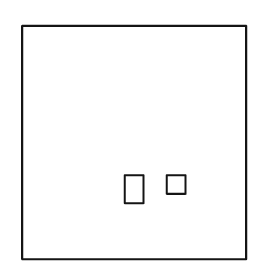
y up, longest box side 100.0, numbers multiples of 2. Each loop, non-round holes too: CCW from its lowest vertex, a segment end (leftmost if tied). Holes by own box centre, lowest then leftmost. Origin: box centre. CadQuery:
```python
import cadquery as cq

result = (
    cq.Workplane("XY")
    .moveTo(-48.0, -50.0)
    .lineTo(48.0, -50.0)
    .lineTo(48.0, 50.0)
    .lineTo(-48.0, 50.0)
    .close()
    .moveTo(-4.0, -26.0)
    .lineTo(4.0, -26.0)
    .lineTo(4.0, -14.0)
    .lineTo(-4.0, -14.0)
    .close()
    .moveTo(14.0, -22.0)
    .lineTo(22.0, -22.0)
    .lineTo(22.0, -14.0)
    .lineTo(14.0, -14.0)
    .close()
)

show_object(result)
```